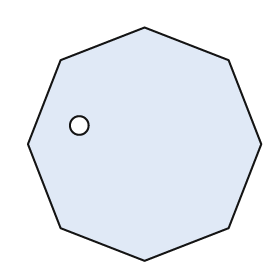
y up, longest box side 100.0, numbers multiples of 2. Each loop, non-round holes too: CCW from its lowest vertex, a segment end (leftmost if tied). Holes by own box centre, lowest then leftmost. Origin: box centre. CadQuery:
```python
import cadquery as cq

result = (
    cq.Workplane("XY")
    .moveTo(0.0, -50.0)
    .lineTo(36.0, -36.0)
    .lineTo(50.0, 0.0)
    .lineTo(36.0, 36.0)
    .lineTo(0.0, 50.0)
    .lineTo(-36.0, 36.0)
    .lineTo(-50.0, 0.0)
    .lineTo(-36.0, -36.0)
    .close()
    .moveTo(-28.0, 8.0)
    .circle(4.0)
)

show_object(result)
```